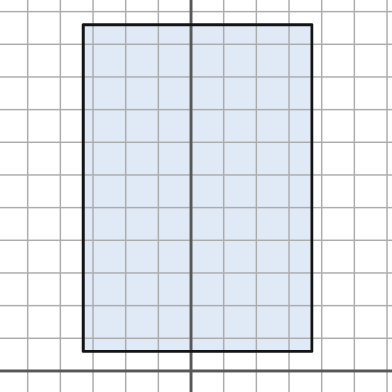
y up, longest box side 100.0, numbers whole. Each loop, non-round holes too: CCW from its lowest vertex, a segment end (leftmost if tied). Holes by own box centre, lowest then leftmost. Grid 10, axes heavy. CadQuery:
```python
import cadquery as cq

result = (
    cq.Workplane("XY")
    .moveTo(-33.0, 6.0)
    .lineTo(37.0, 6.0)
    .lineTo(37.0, 106.0)
    .lineTo(-33.0, 106.0)
    .close()
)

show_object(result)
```